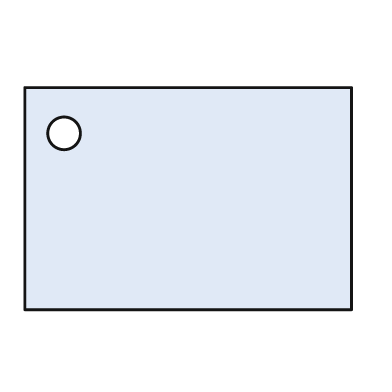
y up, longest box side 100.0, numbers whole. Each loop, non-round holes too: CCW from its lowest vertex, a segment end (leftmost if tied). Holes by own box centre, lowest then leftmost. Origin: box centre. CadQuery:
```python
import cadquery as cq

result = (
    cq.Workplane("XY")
    .moveTo(-50.0, -34.0)
    .lineTo(50.0, -34.0)
    .lineTo(50.0, 34.0)
    .lineTo(-50.0, 34.0)
    .close()
    .moveTo(-38.0, 20.0)
    .circle(5.0)
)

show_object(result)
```